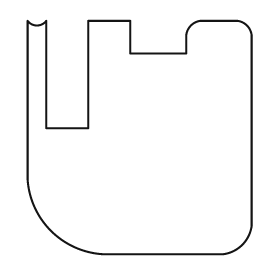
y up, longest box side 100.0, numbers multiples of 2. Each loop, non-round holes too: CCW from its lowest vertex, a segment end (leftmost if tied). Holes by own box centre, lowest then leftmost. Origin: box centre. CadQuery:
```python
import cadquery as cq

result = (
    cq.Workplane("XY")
    .moveTo(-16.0, -50.0)
    .lineTo(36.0, -50.0)
    .threePointArc((44.0, -46.0), (48.0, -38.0))
    .lineTo(48.0, 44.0)
    .threePointArc((46.0, 48.0), (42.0, 50.0))
    .lineTo(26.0, 50.0)
    .threePointArc((22.0, 48.0), (20.0, 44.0))
    .lineTo(20.0, 36.0)
    .lineTo(-4.0, 36.0)
    .lineTo(-4.0, 50.0)
    .lineTo(-22.0, 50.0)
    .lineTo(-22.0, 4.0)
    .lineTo(-40.0, 4.0)
    .lineTo(-40.0, 50.0)
    .threePointArc((-44.0, 48.0), (-48.0, 50.0))
    .lineTo(-48.0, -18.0)
    .threePointArc((-38.0, -40.0), (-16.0, -50.0))
    .close()
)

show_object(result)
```